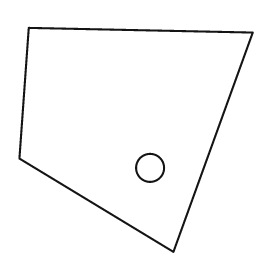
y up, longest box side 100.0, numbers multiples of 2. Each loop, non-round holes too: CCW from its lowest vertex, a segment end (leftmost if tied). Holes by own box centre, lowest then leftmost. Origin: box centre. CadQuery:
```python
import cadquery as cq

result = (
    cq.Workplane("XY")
    .moveTo(16.0, -48.0)
    .lineTo(50.0, 46.0)
    .lineTo(-46.0, 48.0)
    .lineTo(-50.0, -8.0)
    .close()
    .moveTo(6.0, -12.0)
    .circle(6.0)
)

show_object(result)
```